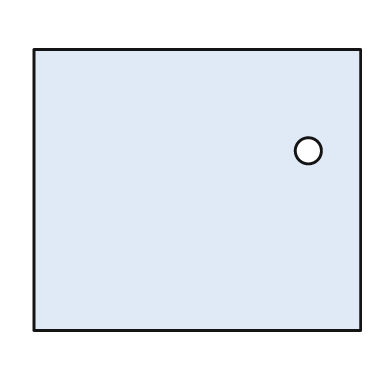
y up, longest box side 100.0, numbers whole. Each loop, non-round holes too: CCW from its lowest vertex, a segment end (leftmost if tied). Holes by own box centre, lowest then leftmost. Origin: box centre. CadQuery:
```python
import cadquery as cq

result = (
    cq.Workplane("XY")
    .moveTo(-50.0, -43.0)
    .lineTo(50.0, -43.0)
    .lineTo(50.0, 43.0)
    .lineTo(-50.0, 43.0)
    .close()
    .moveTo(34.0, 12.0)
    .circle(4.0)
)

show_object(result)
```